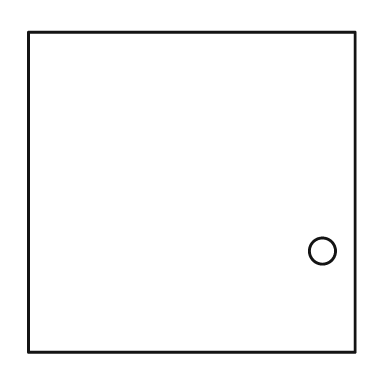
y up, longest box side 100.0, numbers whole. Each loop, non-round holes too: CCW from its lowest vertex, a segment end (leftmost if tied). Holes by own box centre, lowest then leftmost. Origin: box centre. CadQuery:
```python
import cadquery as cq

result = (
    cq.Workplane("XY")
    .moveTo(-50.0, -49.0)
    .lineTo(50.0, -49.0)
    .lineTo(50.0, 49.0)
    .lineTo(-50.0, 49.0)
    .close()
    .moveTo(40.0, -18.0)
    .circle(4.0)
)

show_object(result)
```